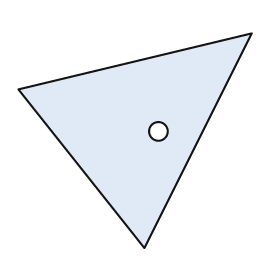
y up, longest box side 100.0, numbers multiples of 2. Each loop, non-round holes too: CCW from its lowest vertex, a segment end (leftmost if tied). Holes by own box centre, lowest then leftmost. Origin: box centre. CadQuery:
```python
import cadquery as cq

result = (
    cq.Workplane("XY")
    .moveTo(4.0, -46.0)
    .lineTo(50.0, 46.0)
    .lineTo(-50.0, 22.0)
    .close()
    .moveTo(10.0, 4.0)
    .circle(4.0)
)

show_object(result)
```